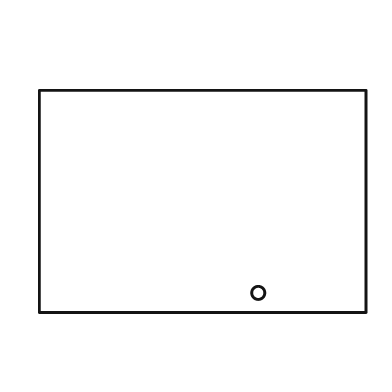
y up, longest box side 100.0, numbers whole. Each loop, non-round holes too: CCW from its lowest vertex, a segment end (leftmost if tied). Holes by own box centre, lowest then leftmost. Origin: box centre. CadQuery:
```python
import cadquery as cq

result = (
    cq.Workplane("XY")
    .moveTo(-50.0, -34.0)
    .lineTo(50.0, -34.0)
    .lineTo(50.0, 34.0)
    .lineTo(-50.0, 34.0)
    .close()
    .moveTo(17.0, -28.0)
    .circle(2.0)
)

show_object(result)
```